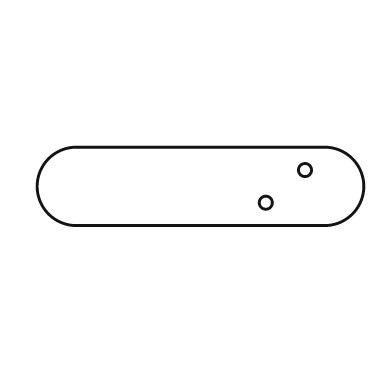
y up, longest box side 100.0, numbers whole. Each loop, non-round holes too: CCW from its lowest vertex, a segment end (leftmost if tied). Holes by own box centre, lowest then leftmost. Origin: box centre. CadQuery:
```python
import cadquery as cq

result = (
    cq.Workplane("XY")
    .moveTo(-38.0, -12.0)
    .lineTo(38.0, -12.0)
    .threePointArc((50.0, 0.0), (38.0, 12.0))
    .lineTo(-38.0, 12.0)
    .threePointArc((-50.0, 0.0), (-38.0, -12.0))
    .close()
    .moveTo(20.0, -5.0)
    .circle(2.0)
    .moveTo(32.0, 5.0)
    .circle(2.0)
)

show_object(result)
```